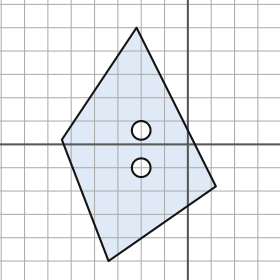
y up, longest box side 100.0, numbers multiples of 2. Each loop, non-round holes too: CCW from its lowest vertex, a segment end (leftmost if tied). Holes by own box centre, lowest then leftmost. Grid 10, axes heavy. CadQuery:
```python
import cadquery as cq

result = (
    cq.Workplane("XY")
    .moveTo(-34.0, -50.0)
    .lineTo(12.0, -18.0)
    .lineTo(-22.0, 50.0)
    .lineTo(-54.0, 2.0)
    .close()
    .moveTo(-20.0, -10.0)
    .circle(4.0)
    .moveTo(-20.0, 6.0)
    .circle(4.0)
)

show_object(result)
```